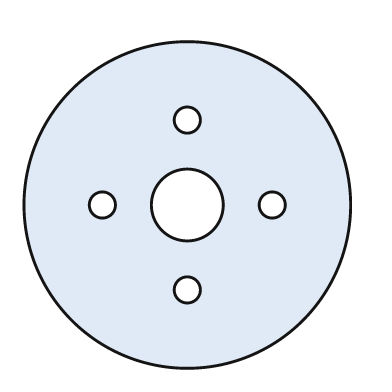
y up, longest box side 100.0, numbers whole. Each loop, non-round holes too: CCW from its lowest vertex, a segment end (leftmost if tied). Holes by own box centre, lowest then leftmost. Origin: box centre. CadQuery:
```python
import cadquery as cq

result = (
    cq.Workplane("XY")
    .moveTo(0.0, 0.0)
    .circle(50.0)
    .moveTo(0.0, -26.0)
    .circle(4.0)
    .moveTo(-26.0, 0.0)
    .circle(4.0)
    .moveTo(0.0, 0.0)
    .circle(11.0)
    .moveTo(26.0, 0.0)
    .circle(4.0)
    .moveTo(0.0, 26.0)
    .circle(4.0)
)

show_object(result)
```